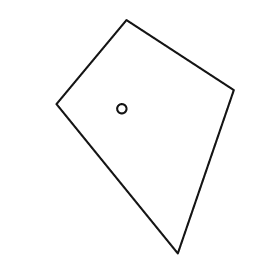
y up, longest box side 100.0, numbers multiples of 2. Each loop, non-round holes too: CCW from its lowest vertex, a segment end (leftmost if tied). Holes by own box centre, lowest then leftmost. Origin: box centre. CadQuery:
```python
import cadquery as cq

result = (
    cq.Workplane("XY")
    .moveTo(14.0, -50.0)
    .lineTo(38.0, 20.0)
    .lineTo(-8.0, 50.0)
    .lineTo(-38.0, 14.0)
    .close()
    .moveTo(-10.0, 12.0)
    .circle(2.0)
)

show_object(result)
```